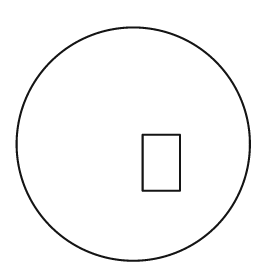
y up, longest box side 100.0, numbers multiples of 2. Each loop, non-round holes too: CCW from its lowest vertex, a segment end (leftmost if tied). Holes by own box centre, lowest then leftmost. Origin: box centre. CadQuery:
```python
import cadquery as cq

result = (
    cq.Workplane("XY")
    .moveTo(0.0, 0.0)
    .circle(50.0)
    .moveTo(4.0, -20.0)
    .lineTo(20.0, -20.0)
    .lineTo(20.0, 4.0)
    .lineTo(4.0, 4.0)
    .close()
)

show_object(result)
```